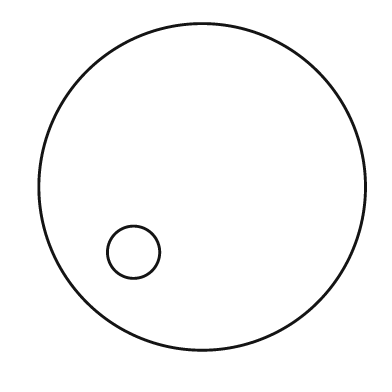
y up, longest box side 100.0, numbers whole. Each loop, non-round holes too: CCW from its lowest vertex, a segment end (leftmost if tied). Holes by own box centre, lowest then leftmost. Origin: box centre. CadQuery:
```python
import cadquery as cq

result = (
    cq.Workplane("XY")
    .moveTo(0.0, 0.0)
    .circle(50.0)
    .moveTo(-21.0, -20.0)
    .circle(8.0)
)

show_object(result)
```